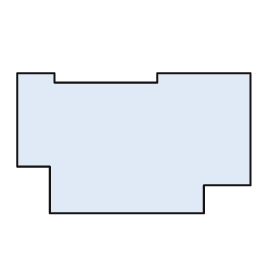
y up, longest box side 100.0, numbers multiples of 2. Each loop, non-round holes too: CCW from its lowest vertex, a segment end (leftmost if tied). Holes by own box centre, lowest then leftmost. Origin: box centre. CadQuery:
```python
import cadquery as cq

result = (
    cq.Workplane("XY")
    .moveTo(-36.0, -30.0)
    .lineTo(30.0, -30.0)
    .lineTo(30.0, -18.0)
    .lineTo(50.0, -18.0)
    .lineTo(50.0, 30.0)
    .lineTo(10.0, 30.0)
    .lineTo(10.0, 26.0)
    .lineTo(-34.0, 26.0)
    .lineTo(-34.0, 30.0)
    .lineTo(-50.0, 30.0)
    .lineTo(-50.0, -10.0)
    .lineTo(-36.0, -10.0)
    .close()
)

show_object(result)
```